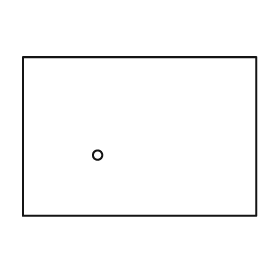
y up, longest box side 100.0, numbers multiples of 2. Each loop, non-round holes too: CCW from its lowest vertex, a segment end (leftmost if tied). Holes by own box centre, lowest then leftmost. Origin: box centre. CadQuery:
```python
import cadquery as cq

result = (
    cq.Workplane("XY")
    .moveTo(-50.0, -34.0)
    .lineTo(50.0, -34.0)
    .lineTo(50.0, 34.0)
    .lineTo(-50.0, 34.0)
    .close()
    .moveTo(-18.0, -8.0)
    .circle(2.0)
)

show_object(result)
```